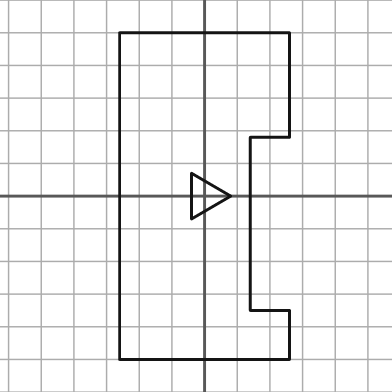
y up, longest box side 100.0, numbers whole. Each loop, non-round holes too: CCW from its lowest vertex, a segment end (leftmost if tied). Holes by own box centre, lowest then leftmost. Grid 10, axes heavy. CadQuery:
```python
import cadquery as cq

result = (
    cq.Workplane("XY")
    .moveTo(-26.0, -50.0)
    .lineTo(26.0, -50.0)
    .lineTo(26.0, -35.0)
    .lineTo(14.0, -35.0)
    .lineTo(14.0, 18.0)
    .lineTo(26.0, 18.0)
    .lineTo(26.0, 50.0)
    .lineTo(-26.0, 50.0)
    .close()
    .moveTo(-4.0, -7.0)
    .lineTo(8.0, 0.0)
    .lineTo(-4.0, 7.0)
    .close()
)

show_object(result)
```